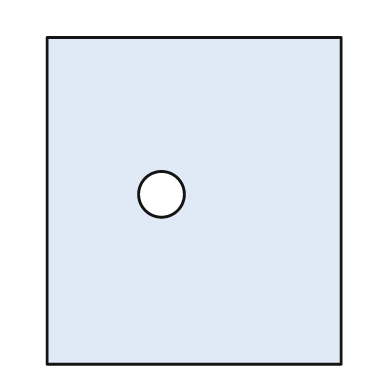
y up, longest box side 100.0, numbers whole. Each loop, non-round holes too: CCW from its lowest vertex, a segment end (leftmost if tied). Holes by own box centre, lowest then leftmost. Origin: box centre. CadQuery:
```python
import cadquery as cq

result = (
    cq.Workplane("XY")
    .moveTo(-45.0, -50.0)
    .lineTo(45.0, -50.0)
    .lineTo(45.0, 50.0)
    .lineTo(-45.0, 50.0)
    .close()
    .moveTo(-10.0, 2.0)
    .circle(7.0)
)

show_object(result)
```